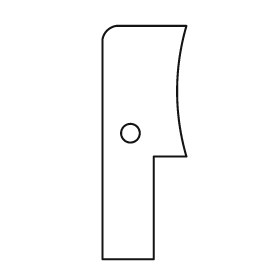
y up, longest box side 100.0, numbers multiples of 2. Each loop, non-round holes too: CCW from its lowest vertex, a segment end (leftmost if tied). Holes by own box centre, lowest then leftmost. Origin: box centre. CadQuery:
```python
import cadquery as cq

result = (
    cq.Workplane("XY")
    .moveTo(-18.0, -50.0)
    .lineTo(4.0, -50.0)
    .lineTo(4.0, -6.0)
    .lineTo(18.0, -6.0)
    .threePointArc((14.0, 22.0), (18.0, 50.0))
    .lineTo(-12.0, 50.0)
    .threePointArc((-16.0, 48.0), (-18.0, 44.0))
    .close()
    .moveTo(-6.0, 4.0)
    .circle(4.0)
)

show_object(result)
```